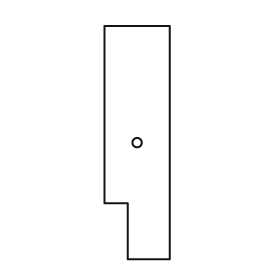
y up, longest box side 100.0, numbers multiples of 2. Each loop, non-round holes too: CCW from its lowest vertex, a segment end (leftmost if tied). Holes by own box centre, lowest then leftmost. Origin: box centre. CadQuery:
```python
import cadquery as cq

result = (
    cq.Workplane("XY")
    .moveTo(-4.0, -50.0)
    .lineTo(14.0, -50.0)
    .lineTo(14.0, 50.0)
    .lineTo(-14.0, 50.0)
    .lineTo(-14.0, -26.0)
    .lineTo(-4.0, -26.0)
    .close()
    .moveTo(0.0, 0.0)
    .circle(2.0)
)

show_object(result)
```